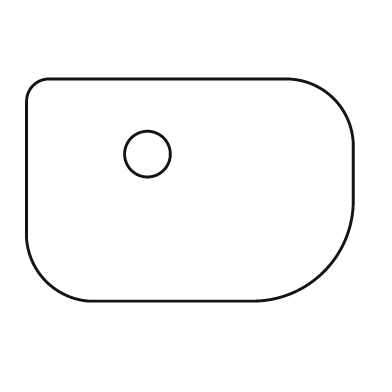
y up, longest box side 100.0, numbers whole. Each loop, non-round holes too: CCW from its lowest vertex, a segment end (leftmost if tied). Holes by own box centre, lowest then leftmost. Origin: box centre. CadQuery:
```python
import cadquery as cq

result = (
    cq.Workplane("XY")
    .moveTo(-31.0, -34.0)
    .lineTo(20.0, -34.0)
    .threePointArc((41.0, -25.0), (50.0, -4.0))
    .lineTo(50.0, 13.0)
    .threePointArc((44.0, 28.0), (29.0, 34.0))
    .lineTo(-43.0, 34.0)
    .threePointArc((-48.0, 32.0), (-50.0, 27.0))
    .lineTo(-50.0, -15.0)
    .threePointArc((-44.0, -28.0), (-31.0, -34.0))
    .close()
    .moveTo(-13.0, 11.0)
    .circle(7.0)
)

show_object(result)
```